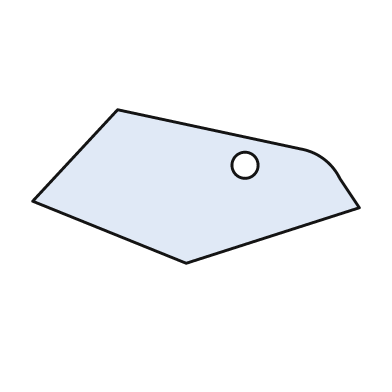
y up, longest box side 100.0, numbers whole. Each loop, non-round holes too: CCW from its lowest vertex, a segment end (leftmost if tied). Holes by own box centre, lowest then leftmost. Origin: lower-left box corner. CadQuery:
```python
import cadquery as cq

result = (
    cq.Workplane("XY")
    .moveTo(47.0, 0.0)
    .lineTo(100.0, 17.0)
    .lineTo(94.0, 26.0)
    .threePointArc((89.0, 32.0), (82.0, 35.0))
    .lineTo(26.0, 47.0)
    .lineTo(0.0, 19.0)
    .close()
    .moveTo(65.0, 30.0)
    .circle(4.0)
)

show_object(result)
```